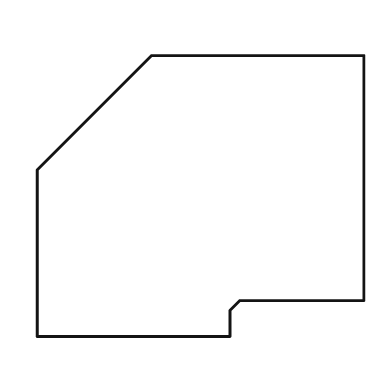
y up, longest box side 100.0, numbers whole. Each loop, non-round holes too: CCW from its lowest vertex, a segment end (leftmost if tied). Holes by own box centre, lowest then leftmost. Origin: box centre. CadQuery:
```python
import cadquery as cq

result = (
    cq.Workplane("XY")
    .moveTo(-50.0, -43.0)
    .lineTo(9.0, -43.0)
    .lineTo(9.0, -35.0)
    .lineTo(12.0, -32.0)
    .lineTo(50.0, -32.0)
    .lineTo(50.0, 43.0)
    .lineTo(-15.0, 43.0)
    .lineTo(-50.0, 8.0)
    .close()
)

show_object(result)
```